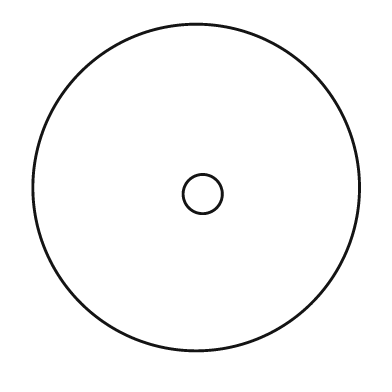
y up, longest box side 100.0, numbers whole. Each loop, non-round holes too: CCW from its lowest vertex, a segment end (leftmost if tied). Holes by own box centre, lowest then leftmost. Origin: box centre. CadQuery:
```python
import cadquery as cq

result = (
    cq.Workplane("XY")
    .moveTo(0.0, 0.0)
    .circle(50.0)
    .moveTo(2.0, -2.0)
    .circle(6.0)
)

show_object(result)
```